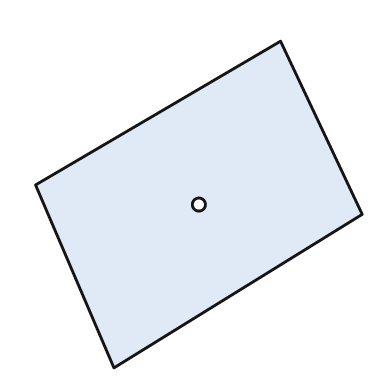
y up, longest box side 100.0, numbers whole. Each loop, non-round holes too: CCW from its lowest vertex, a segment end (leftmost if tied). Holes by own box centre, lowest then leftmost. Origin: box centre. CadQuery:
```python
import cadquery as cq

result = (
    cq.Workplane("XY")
    .moveTo(-26.0, -50.0)
    .lineTo(50.0, -3.0)
    .lineTo(25.0, 50.0)
    .lineTo(-50.0, 6.0)
    .close()
    .moveTo(0.0, 0.0)
    .circle(2.0)
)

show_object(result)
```